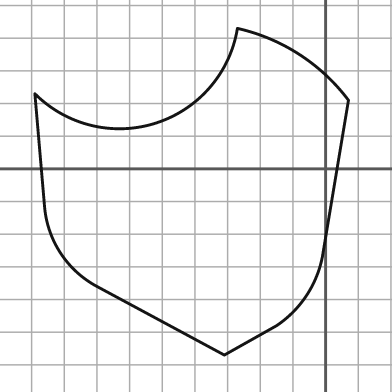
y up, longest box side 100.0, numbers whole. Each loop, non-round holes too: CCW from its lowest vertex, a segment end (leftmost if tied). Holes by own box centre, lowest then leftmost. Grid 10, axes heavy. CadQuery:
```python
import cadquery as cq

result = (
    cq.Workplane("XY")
    .moveTo(-31.0, -57.0)
    .lineTo(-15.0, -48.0)
    .threePointArc((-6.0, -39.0), (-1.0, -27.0))
    .lineTo(7.0, 21.0)
    .threePointArc((-8.0, 35.0), (-27.0, 43.0))
    .threePointArc((-52.0, 14.0), (-89.0, 23.0))
    .lineTo(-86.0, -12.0)
    .threePointArc((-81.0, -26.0), (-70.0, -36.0))
    .close()
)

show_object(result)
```